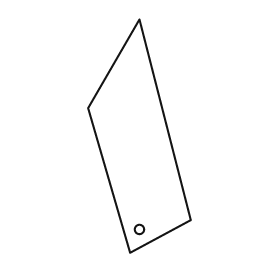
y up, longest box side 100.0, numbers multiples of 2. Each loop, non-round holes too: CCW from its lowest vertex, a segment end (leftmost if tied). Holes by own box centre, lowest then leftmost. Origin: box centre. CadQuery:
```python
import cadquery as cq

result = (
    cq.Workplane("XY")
    .moveTo(-4.0, -50.0)
    .lineTo(22.0, -36.0)
    .lineTo(0.0, 50.0)
    .lineTo(-22.0, 12.0)
    .close()
    .moveTo(0.0, -40.0)
    .circle(2.0)
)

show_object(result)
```